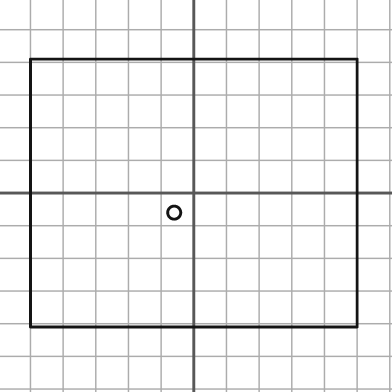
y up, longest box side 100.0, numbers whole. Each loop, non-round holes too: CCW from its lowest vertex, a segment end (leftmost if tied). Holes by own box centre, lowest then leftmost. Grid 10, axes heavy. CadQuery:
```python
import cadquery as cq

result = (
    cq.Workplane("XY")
    .moveTo(-50.0, -41.0)
    .lineTo(50.0, -41.0)
    .lineTo(50.0, 41.0)
    .lineTo(-50.0, 41.0)
    .close()
    .moveTo(-6.0, -6.0)
    .circle(2.0)
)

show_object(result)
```